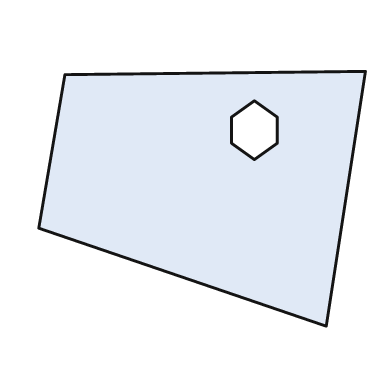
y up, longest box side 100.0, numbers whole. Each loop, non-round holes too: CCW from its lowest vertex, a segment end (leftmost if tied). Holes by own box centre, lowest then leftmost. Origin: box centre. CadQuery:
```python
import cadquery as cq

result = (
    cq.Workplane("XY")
    .moveTo(38.0, -39.0)
    .lineTo(50.0, 39.0)
    .lineTo(-42.0, 38.0)
    .lineTo(-50.0, -9.0)
    .close()
    .moveTo(16.0, 12.0)
    .lineTo(23.0, 17.0)
    .lineTo(23.0, 25.0)
    .lineTo(16.0, 30.0)
    .lineTo(9.0, 25.0)
    .lineTo(9.0, 17.0)
    .close()
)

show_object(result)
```